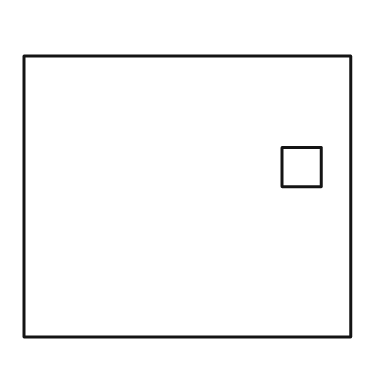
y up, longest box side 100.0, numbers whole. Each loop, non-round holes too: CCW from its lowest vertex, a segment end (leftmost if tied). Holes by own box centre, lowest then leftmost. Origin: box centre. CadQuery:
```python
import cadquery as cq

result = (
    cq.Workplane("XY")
    .moveTo(-50.0, -43.0)
    .lineTo(50.0, -43.0)
    .lineTo(50.0, 43.0)
    .lineTo(-50.0, 43.0)
    .close()
    .moveTo(29.0, 3.0)
    .lineTo(41.0, 3.0)
    .lineTo(41.0, 15.0)
    .lineTo(29.0, 15.0)
    .close()
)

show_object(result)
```